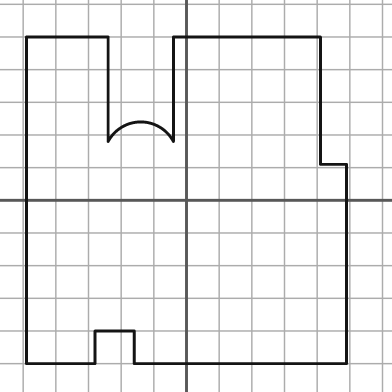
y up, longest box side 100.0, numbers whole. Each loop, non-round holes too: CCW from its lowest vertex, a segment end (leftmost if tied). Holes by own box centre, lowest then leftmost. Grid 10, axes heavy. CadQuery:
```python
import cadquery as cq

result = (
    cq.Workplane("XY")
    .moveTo(-49.0, -50.0)
    .lineTo(-28.0, -50.0)
    .lineTo(-28.0, -40.0)
    .lineTo(-16.0, -40.0)
    .lineTo(-16.0, -50.0)
    .lineTo(49.0, -50.0)
    .lineTo(49.0, 11.0)
    .lineTo(41.0, 11.0)
    .lineTo(41.0, 50.0)
    .lineTo(-4.0, 50.0)
    .lineTo(-4.0, 18.0)
    .threePointArc((-14.0, 24.0), (-24.0, 18.0))
    .lineTo(-24.0, 50.0)
    .lineTo(-49.0, 50.0)
    .close()
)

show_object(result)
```